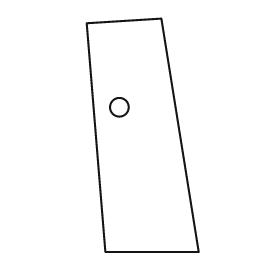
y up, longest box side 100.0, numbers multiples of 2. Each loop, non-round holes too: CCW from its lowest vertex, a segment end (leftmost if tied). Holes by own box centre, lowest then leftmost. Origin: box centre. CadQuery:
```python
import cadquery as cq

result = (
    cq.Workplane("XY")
    .moveTo(-16.0, -50.0)
    .lineTo(24.0, -50.0)
    .lineTo(8.0, 50.0)
    .lineTo(-24.0, 48.0)
    .close()
    .moveTo(-10.0, 12.0)
    .circle(4.0)
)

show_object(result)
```